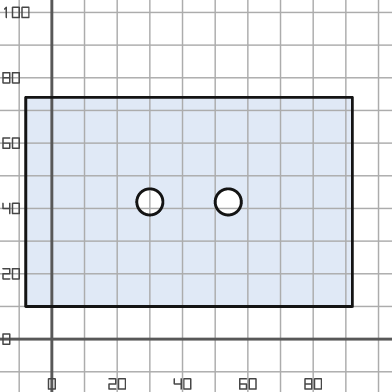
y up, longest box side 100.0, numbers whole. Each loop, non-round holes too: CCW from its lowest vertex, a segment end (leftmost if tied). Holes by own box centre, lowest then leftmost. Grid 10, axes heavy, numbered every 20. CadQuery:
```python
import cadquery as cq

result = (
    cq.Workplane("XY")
    .moveTo(-8.0, 10.0)
    .lineTo(92.0, 10.0)
    .lineTo(92.0, 74.0)
    .lineTo(-8.0, 74.0)
    .close()
    .moveTo(30.0, 42.0)
    .circle(4.0)
    .moveTo(54.0, 42.0)
    .circle(4.0)
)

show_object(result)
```